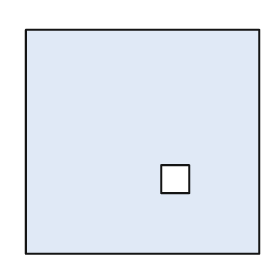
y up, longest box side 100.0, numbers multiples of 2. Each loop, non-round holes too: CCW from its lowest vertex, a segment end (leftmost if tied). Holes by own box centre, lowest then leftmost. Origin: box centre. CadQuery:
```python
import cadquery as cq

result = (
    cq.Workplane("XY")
    .moveTo(-50.0, -48.0)
    .lineTo(50.0, -48.0)
    .lineTo(50.0, 48.0)
    .lineTo(-50.0, 48.0)
    .close()
    .moveTo(8.0, -22.0)
    .lineTo(20.0, -22.0)
    .lineTo(20.0, -10.0)
    .lineTo(8.0, -10.0)
    .close()
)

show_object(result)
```